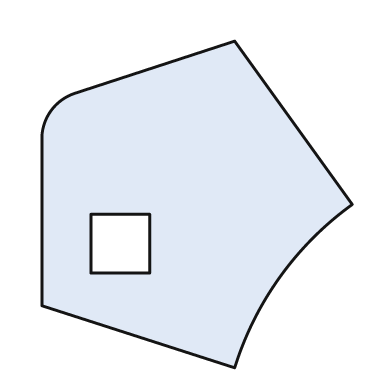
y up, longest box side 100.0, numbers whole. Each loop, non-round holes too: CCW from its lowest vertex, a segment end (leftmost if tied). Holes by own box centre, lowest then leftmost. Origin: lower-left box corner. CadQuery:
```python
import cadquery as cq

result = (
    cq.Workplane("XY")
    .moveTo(59.0, 0.0)
    .threePointArc((73.0, 28.0), (95.0, 50.0))
    .lineTo(59.0, 100.0)
    .lineTo(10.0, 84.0)
    .threePointArc((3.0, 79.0), (0.0, 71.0))
    .lineTo(0.0, 19.0)
    .close()
    .moveTo(15.0, 29.0)
    .lineTo(33.0, 29.0)
    .lineTo(33.0, 47.0)
    .lineTo(15.0, 47.0)
    .close()
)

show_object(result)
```